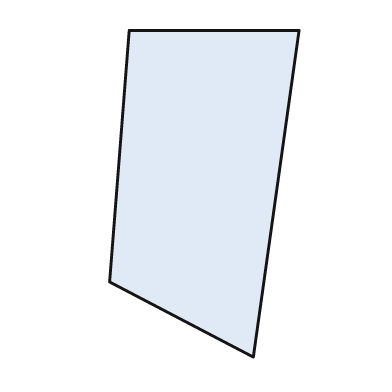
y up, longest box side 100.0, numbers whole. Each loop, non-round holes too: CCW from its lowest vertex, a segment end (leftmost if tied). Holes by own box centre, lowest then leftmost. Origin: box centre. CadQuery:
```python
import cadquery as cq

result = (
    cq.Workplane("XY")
    .moveTo(15.0, -50.0)
    .lineTo(29.0, 50.0)
    .lineTo(-23.0, 50.0)
    .lineTo(-29.0, -27.0)
    .close()
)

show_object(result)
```